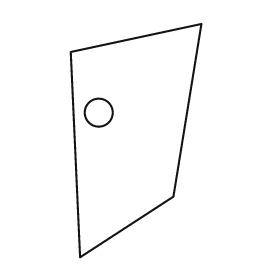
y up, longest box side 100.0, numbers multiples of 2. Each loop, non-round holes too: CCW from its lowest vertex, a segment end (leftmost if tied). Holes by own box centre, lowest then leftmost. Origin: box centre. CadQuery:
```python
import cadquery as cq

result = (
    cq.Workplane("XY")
    .moveTo(-24.0, -50.0)
    .lineTo(16.0, -24.0)
    .lineTo(28.0, 50.0)
    .lineTo(-28.0, 38.0)
    .close()
    .moveTo(-16.0, 12.0)
    .circle(6.0)
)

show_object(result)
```